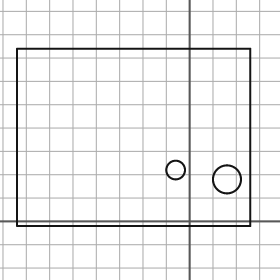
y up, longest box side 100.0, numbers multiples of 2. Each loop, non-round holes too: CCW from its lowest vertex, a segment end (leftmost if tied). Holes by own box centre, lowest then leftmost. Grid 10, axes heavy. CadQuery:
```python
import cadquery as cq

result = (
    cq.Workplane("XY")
    .moveTo(-74.0, -2.0)
    .lineTo(26.0, -2.0)
    .lineTo(26.0, 74.0)
    .lineTo(-74.0, 74.0)
    .close()
    .moveTo(16.0, 18.0)
    .circle(6.0)
    .moveTo(-6.0, 22.0)
    .circle(4.0)
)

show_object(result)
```